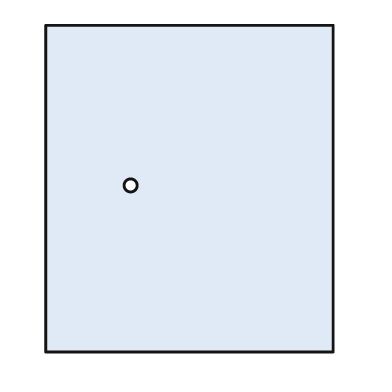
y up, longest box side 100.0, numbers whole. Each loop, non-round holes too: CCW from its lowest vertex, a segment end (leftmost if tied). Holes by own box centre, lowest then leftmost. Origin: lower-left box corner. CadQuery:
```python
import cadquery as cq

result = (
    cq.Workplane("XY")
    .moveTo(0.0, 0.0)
    .lineTo(88.0, 0.0)
    .lineTo(88.0, 100.0)
    .lineTo(0.0, 100.0)
    .close()
    .moveTo(26.0, 51.0)
    .circle(2.0)
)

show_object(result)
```